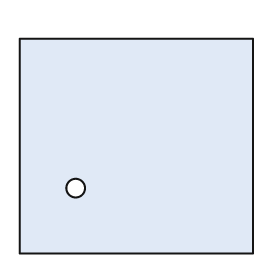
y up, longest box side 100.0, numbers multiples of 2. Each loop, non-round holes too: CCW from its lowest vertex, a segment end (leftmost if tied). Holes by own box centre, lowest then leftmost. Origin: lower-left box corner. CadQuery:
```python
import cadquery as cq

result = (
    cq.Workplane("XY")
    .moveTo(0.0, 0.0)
    .lineTo(100.0, 0.0)
    .lineTo(100.0, 92.0)
    .lineTo(0.0, 92.0)
    .close()
    .moveTo(24.0, 28.0)
    .circle(4.0)
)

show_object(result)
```